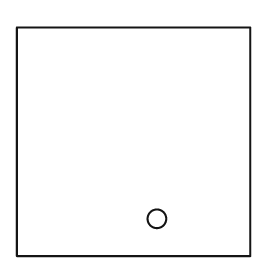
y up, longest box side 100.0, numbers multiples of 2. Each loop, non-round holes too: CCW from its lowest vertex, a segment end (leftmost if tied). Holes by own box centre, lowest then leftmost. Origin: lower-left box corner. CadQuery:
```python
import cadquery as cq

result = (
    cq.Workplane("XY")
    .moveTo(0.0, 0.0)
    .lineTo(100.0, 0.0)
    .lineTo(100.0, 98.0)
    .lineTo(0.0, 98.0)
    .close()
    .moveTo(60.0, 16.0)
    .circle(4.0)
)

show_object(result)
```